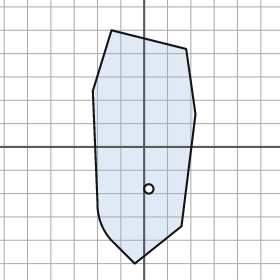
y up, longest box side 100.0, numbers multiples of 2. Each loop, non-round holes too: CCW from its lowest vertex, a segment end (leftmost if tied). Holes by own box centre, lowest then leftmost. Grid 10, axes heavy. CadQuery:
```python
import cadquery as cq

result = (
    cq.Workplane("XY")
    .moveTo(-4.0, -50.0)
    .lineTo(16.0, -34.0)
    .lineTo(22.0, 14.0)
    .lineTo(18.0, 42.0)
    .lineTo(-14.0, 50.0)
    .lineTo(-22.0, 24.0)
    .lineTo(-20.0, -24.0)
    .threePointArc((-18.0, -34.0), (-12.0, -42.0))
    .close()
    .moveTo(2.0, -18.0)
    .circle(2.0)
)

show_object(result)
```